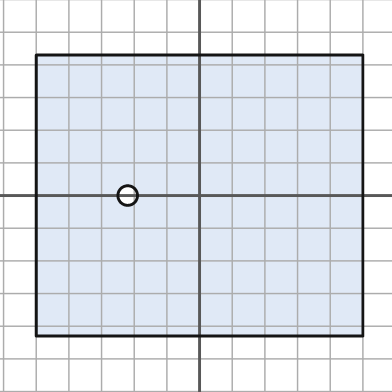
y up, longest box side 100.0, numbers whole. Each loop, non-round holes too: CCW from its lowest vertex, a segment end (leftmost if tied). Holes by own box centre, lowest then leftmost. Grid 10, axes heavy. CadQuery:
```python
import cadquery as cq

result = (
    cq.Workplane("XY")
    .moveTo(-50.0, -43.0)
    .lineTo(50.0, -43.0)
    .lineTo(50.0, 43.0)
    .lineTo(-50.0, 43.0)
    .close()
    .moveTo(-22.0, 0.0)
    .circle(3.0)
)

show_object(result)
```